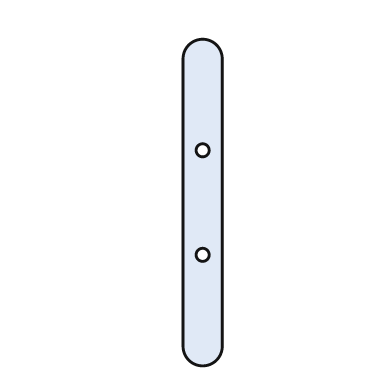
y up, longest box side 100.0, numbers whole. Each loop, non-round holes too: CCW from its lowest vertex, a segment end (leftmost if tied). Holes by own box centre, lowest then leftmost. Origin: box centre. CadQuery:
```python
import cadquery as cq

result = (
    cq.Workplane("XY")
    .moveTo(-6.0, -44.0)
    .threePointArc((0.0, -50.0), (6.0, -44.0))
    .lineTo(6.0, 44.0)
    .threePointArc((0.0, 50.0), (-6.0, 44.0))
    .close()
    .moveTo(0.0, -16.0)
    .circle(2.0)
    .moveTo(0.0, 16.0)
    .circle(2.0)
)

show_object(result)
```